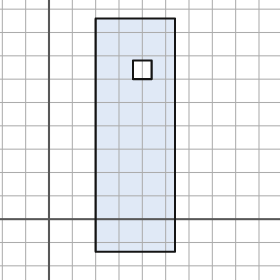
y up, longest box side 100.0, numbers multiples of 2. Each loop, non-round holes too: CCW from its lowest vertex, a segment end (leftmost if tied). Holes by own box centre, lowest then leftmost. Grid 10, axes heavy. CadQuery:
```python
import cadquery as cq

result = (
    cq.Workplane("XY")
    .moveTo(20.0, -14.0)
    .lineTo(54.0, -14.0)
    .lineTo(54.0, 86.0)
    .lineTo(20.0, 86.0)
    .close()
    .moveTo(36.0, 60.0)
    .lineTo(44.0, 60.0)
    .lineTo(44.0, 68.0)
    .lineTo(36.0, 68.0)
    .close()
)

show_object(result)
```